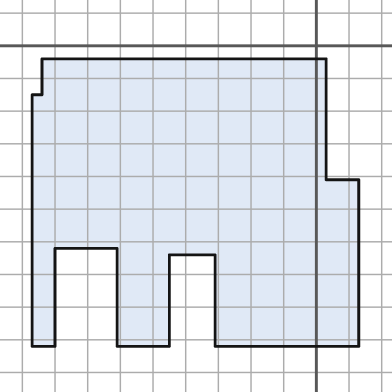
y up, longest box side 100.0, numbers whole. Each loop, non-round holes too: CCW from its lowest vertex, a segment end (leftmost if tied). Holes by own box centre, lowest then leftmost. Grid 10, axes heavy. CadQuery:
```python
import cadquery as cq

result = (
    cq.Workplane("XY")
    .moveTo(-87.0, -92.0)
    .lineTo(-80.0, -92.0)
    .lineTo(-80.0, -62.0)
    .lineTo(-61.0, -62.0)
    .lineTo(-61.0, -92.0)
    .lineTo(-45.0, -92.0)
    .lineTo(-45.0, -64.0)
    .lineTo(-31.0, -64.0)
    .lineTo(-31.0, -92.0)
    .lineTo(13.0, -92.0)
    .lineTo(13.0, -41.0)
    .lineTo(3.0, -41.0)
    .lineTo(3.0, -4.0)
    .lineTo(-84.0, -4.0)
    .lineTo(-84.0, -15.0)
    .lineTo(-87.0, -15.0)
    .close()
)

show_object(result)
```